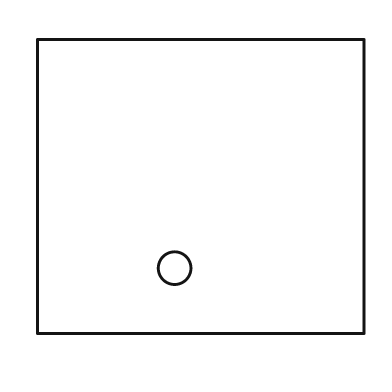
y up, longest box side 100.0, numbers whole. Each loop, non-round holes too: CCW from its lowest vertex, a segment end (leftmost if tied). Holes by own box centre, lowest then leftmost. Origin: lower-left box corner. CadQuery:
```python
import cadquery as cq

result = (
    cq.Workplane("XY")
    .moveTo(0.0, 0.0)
    .lineTo(100.0, 0.0)
    .lineTo(100.0, 90.0)
    .lineTo(0.0, 90.0)
    .close()
    .moveTo(42.0, 20.0)
    .circle(5.0)
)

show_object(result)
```